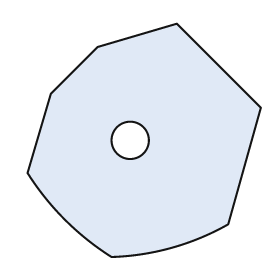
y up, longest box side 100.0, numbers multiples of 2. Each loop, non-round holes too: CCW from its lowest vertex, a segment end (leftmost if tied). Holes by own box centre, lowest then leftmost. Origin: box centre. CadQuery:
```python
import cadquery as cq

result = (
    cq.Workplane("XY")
    .moveTo(-14.0, -50.0)
    .threePointArc((12.0, -46.0), (36.0, -36.0))
    .lineTo(50.0, 14.0)
    .lineTo(14.0, 50.0)
    .lineTo(-20.0, 40.0)
    .lineTo(-40.0, 20.0)
    .lineTo(-50.0, -14.0)
    .threePointArc((-34.0, -34.0), (-14.0, -50.0))
    .close()
    .moveTo(-6.0, 0.0)
    .circle(8.0)
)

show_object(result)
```